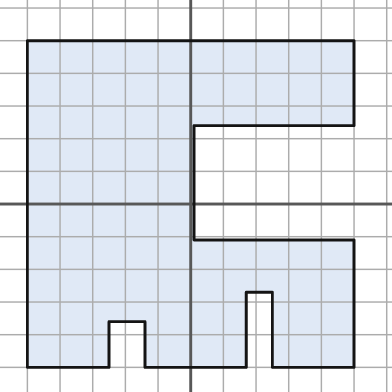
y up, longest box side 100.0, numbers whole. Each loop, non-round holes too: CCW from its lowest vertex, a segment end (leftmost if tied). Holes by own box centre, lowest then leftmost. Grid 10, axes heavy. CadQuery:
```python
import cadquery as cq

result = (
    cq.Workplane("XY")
    .moveTo(-50.0, -50.0)
    .lineTo(-25.0, -50.0)
    .lineTo(-25.0, -36.0)
    .lineTo(-14.0, -36.0)
    .lineTo(-14.0, -50.0)
    .lineTo(17.0, -50.0)
    .lineTo(17.0, -27.0)
    .lineTo(25.0, -27.0)
    .lineTo(25.0, -50.0)
    .lineTo(50.0, -50.0)
    .lineTo(50.0, -11.0)
    .lineTo(1.0, -11.0)
    .lineTo(1.0, 24.0)
    .lineTo(50.0, 24.0)
    .lineTo(50.0, 50.0)
    .lineTo(-50.0, 50.0)
    .close()
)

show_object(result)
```